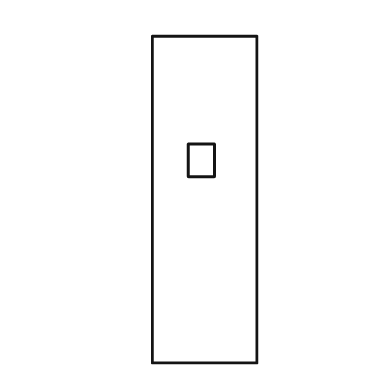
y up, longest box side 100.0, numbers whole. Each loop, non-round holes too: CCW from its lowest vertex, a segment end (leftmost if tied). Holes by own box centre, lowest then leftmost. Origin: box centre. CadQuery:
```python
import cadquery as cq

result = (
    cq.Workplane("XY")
    .moveTo(-16.0, -50.0)
    .lineTo(16.0, -50.0)
    .lineTo(16.0, 50.0)
    .lineTo(-16.0, 50.0)
    .close()
    .moveTo(-5.0, 7.0)
    .lineTo(3.0, 7.0)
    .lineTo(3.0, 17.0)
    .lineTo(-5.0, 17.0)
    .close()
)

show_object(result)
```